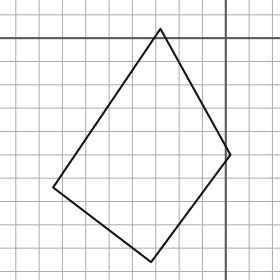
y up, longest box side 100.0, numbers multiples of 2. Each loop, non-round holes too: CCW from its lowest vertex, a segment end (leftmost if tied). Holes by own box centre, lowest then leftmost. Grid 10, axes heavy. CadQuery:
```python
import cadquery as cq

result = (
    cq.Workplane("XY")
    .moveTo(-32.0, -96.0)
    .lineTo(2.0, -50.0)
    .lineTo(-28.0, 4.0)
    .lineTo(-74.0, -64.0)
    .close()
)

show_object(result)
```